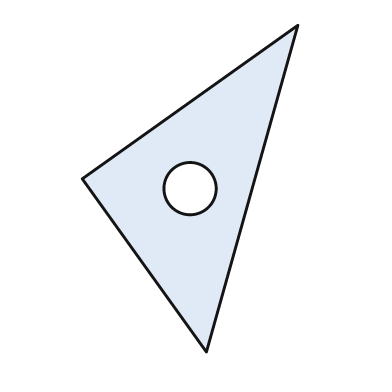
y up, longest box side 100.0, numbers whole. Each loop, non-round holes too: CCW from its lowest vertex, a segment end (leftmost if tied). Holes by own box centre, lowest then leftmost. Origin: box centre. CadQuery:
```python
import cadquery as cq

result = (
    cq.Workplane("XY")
    .moveTo(5.0, -50.0)
    .lineTo(33.0, 50.0)
    .lineTo(-33.0, 3.0)
    .close()
    .moveTo(0.0, 0.0)
    .circle(8.0)
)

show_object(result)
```